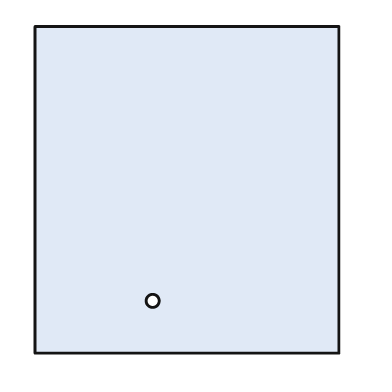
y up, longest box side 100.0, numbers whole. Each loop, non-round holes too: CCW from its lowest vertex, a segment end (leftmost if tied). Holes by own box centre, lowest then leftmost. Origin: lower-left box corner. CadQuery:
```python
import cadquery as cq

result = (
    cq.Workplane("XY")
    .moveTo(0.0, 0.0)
    .lineTo(93.0, 0.0)
    .lineTo(93.0, 100.0)
    .lineTo(0.0, 100.0)
    .close()
    .moveTo(36.0, 16.0)
    .circle(2.0)
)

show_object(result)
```